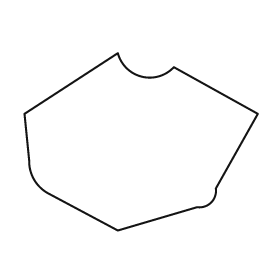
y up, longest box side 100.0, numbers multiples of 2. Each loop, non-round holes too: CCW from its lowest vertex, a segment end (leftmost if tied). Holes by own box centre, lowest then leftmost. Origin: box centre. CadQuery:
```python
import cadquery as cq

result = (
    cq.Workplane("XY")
    .moveTo(-10.0, -38.0)
    .lineTo(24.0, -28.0)
    .threePointArc((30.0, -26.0), (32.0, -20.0))
    .lineTo(50.0, 12.0)
    .lineTo(14.0, 32.0)
    .threePointArc((0.0, 28.0), (-10.0, 38.0))
    .lineTo(-50.0, 12.0)
    .lineTo(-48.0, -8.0)
    .threePointArc((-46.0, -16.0), (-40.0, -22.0))
    .close()
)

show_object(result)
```